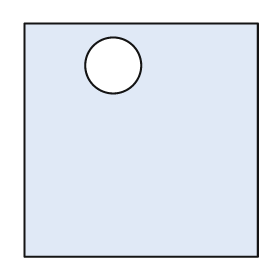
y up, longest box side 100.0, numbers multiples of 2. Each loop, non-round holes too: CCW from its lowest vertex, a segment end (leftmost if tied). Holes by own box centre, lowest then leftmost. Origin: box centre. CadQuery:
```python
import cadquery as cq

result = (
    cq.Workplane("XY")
    .moveTo(-50.0, -50.0)
    .lineTo(50.0, -50.0)
    .lineTo(50.0, 50.0)
    .lineTo(-50.0, 50.0)
    .close()
    .moveTo(-12.0, 32.0)
    .circle(12.0)
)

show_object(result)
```